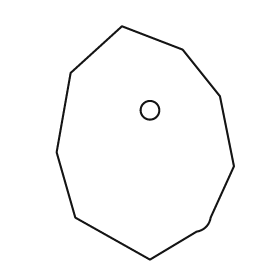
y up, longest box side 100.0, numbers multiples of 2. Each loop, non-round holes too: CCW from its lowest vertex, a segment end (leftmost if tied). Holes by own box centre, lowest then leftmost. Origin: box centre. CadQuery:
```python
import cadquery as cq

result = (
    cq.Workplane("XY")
    .moveTo(2.0, -50.0)
    .lineTo(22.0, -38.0)
    .threePointArc((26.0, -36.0), (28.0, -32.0))
    .lineTo(38.0, -10.0)
    .lineTo(32.0, 20.0)
    .lineTo(16.0, 40.0)
    .lineTo(-10.0, 50.0)
    .lineTo(-32.0, 30.0)
    .lineTo(-38.0, -4.0)
    .lineTo(-30.0, -32.0)
    .close()
    .moveTo(2.0, 14.0)
    .circle(4.0)
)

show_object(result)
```